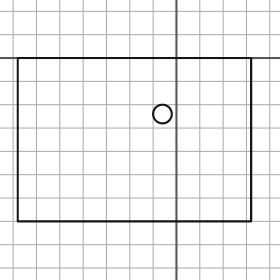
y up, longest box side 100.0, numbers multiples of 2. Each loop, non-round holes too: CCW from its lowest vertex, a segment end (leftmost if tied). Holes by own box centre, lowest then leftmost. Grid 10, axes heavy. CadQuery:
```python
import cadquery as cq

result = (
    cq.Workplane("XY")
    .moveTo(-68.0, -70.0)
    .lineTo(32.0, -70.0)
    .lineTo(32.0, 0.0)
    .lineTo(-68.0, 0.0)
    .close()
    .moveTo(-6.0, -24.0)
    .circle(4.0)
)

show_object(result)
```